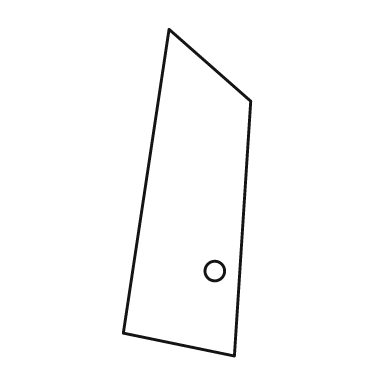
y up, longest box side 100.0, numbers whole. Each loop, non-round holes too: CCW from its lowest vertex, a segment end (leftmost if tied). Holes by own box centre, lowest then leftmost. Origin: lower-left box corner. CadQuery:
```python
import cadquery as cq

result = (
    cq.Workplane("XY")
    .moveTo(34.0, 0.0)
    .lineTo(39.0, 78.0)
    .lineTo(14.0, 100.0)
    .lineTo(0.0, 7.0)
    .close()
    .moveTo(28.0, 26.0)
    .circle(3.0)
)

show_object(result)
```